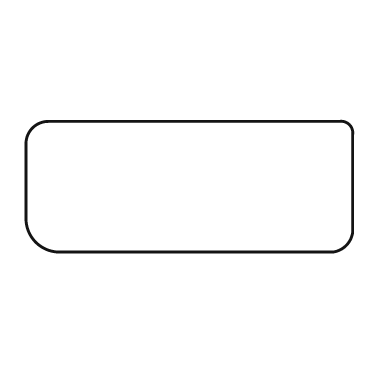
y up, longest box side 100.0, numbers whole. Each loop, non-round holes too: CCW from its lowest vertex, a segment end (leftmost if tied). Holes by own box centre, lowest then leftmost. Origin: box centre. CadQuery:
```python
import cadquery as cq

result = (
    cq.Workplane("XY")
    .moveTo(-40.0, -20.0)
    .lineTo(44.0, -20.0)
    .threePointArc((48.0, -18.0), (50.0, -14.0))
    .lineTo(50.0, 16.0)
    .threePointArc((49.0, 19.0), (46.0, 20.0))
    .lineTo(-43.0, 20.0)
    .threePointArc((-48.0, 18.0), (-50.0, 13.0))
    .lineTo(-50.0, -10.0)
    .threePointArc((-47.0, -17.0), (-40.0, -20.0))
    .close()
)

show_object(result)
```